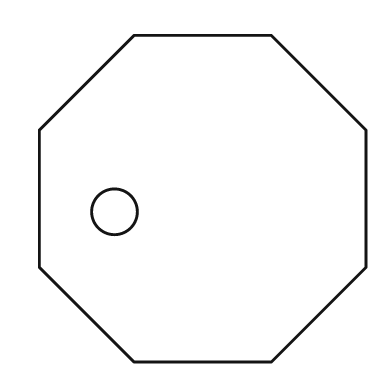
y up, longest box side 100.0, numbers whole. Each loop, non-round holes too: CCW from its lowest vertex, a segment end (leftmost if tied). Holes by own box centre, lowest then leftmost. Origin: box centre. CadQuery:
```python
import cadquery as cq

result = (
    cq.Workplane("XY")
    .moveTo(-21.0, -50.0)
    .lineTo(21.0, -50.0)
    .lineTo(50.0, -21.0)
    .lineTo(50.0, 21.0)
    .lineTo(21.0, 50.0)
    .lineTo(-21.0, 50.0)
    .lineTo(-50.0, 21.0)
    .lineTo(-50.0, -21.0)
    .close()
    .moveTo(-27.0, -4.0)
    .circle(7.0)
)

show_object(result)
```